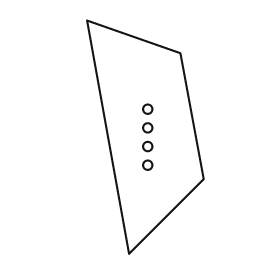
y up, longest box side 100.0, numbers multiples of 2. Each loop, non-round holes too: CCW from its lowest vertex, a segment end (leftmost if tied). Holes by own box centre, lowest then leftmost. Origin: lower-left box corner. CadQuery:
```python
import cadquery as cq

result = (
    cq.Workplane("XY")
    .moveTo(18.0, 0.0)
    .lineTo(50.0, 32.0)
    .lineTo(40.0, 86.0)
    .lineTo(0.0, 100.0)
    .close()
    .moveTo(26.0, 38.0)
    .circle(2.0)
    .moveTo(26.0, 46.0)
    .circle(2.0)
    .moveTo(26.0, 54.0)
    .circle(2.0)
    .moveTo(26.0, 62.0)
    .circle(2.0)
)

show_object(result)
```